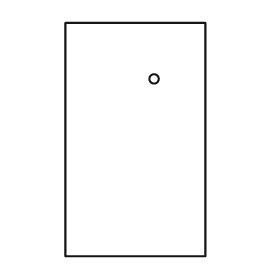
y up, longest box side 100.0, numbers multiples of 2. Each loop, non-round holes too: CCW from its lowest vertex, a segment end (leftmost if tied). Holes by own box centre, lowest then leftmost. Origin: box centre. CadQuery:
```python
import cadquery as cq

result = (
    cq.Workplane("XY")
    .moveTo(-30.0, -50.0)
    .lineTo(30.0, -50.0)
    .lineTo(30.0, 50.0)
    .lineTo(-30.0, 50.0)
    .close()
    .moveTo(8.0, 26.0)
    .circle(2.0)
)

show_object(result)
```